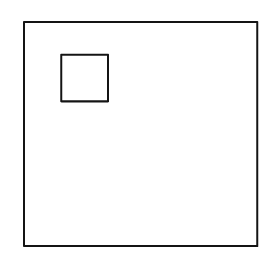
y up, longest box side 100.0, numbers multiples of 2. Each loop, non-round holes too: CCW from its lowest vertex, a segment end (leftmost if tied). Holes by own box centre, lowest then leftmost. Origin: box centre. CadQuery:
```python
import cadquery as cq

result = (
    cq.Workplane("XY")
    .moveTo(-50.0, -48.0)
    .lineTo(50.0, -48.0)
    .lineTo(50.0, 48.0)
    .lineTo(-50.0, 48.0)
    .close()
    .moveTo(-34.0, 14.0)
    .lineTo(-14.0, 14.0)
    .lineTo(-14.0, 34.0)
    .lineTo(-34.0, 34.0)
    .close()
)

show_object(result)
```